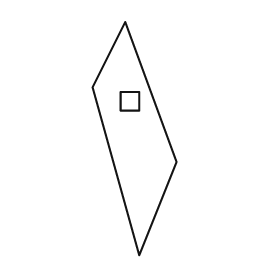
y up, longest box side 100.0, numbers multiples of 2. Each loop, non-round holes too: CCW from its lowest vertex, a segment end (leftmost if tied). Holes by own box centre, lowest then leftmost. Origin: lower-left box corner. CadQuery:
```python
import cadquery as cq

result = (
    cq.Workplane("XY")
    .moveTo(20.0, 0.0)
    .lineTo(36.0, 40.0)
    .lineTo(14.0, 100.0)
    .lineTo(0.0, 72.0)
    .close()
    .moveTo(12.0, 62.0)
    .lineTo(20.0, 62.0)
    .lineTo(20.0, 70.0)
    .lineTo(12.0, 70.0)
    .close()
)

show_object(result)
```